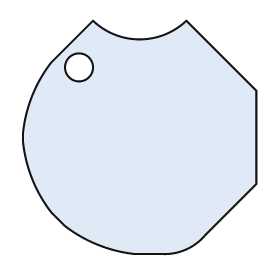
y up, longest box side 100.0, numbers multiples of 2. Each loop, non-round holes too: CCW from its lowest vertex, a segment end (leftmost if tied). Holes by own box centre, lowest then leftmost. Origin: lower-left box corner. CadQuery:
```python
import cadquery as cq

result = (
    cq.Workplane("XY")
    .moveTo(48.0, 0.0)
    .lineTo(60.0, 0.0)
    .threePointArc((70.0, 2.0), (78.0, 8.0))
    .lineTo(100.0, 30.0)
    .lineTo(100.0, 70.0)
    .lineTo(70.0, 100.0)
    .threePointArc((50.0, 92.0), (30.0, 100.0))
    .lineTo(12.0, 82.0)
    .threePointArc((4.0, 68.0), (0.0, 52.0))
    .lineTo(0.0, 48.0)
    .threePointArc((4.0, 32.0), (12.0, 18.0))
    .lineTo(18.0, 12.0)
    .threePointArc((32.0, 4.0), (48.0, 0.0))
    .close()
    .moveTo(24.0, 80.0)
    .circle(6.0)
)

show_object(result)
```